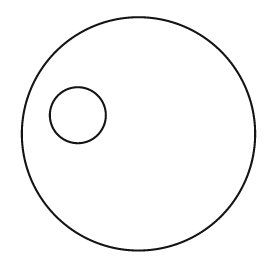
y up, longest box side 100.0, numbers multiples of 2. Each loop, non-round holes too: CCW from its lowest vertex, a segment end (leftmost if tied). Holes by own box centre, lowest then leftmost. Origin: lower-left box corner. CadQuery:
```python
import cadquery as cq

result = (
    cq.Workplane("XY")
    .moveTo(50.0, 50.0)
    .circle(50.0)
    .moveTo(24.0, 58.0)
    .circle(12.0)
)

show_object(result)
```